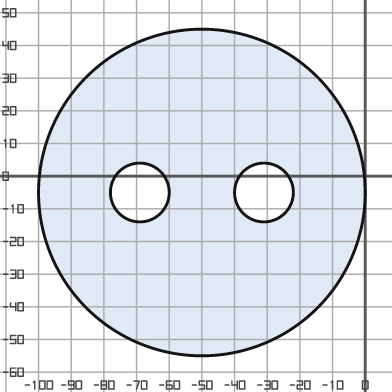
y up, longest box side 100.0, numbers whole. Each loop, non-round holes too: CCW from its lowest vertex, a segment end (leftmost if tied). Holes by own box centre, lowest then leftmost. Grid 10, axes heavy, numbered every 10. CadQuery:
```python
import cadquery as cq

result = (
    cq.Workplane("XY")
    .moveTo(-50.0, -5.0)
    .circle(50.0)
    .moveTo(-69.0, -5.0)
    .circle(9.0)
    .moveTo(-31.0, -5.0)
    .circle(9.0)
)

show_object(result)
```